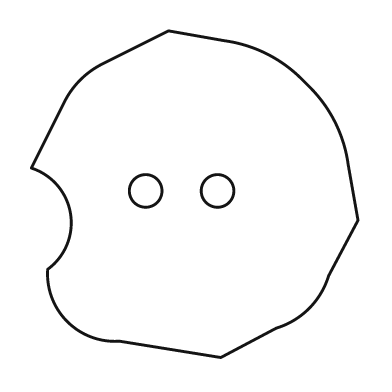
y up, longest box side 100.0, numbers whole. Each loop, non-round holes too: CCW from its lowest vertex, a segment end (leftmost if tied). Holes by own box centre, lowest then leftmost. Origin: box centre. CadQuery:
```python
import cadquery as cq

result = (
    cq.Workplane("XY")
    .moveTo(8.0, -50.0)
    .lineTo(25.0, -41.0)
    .threePointArc((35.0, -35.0), (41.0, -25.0))
    .lineTo(50.0, -8.0)
    .lineTo(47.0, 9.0)
    .threePointArc((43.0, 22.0), (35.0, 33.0))
    .lineTo(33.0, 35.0)
    .threePointArc((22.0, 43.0), (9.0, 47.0))
    .lineTo(-8.0, 50.0)
    .lineTo(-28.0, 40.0)
    .threePointArc((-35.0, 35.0), (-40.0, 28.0))
    .lineTo(-50.0, 8.0)
    .threePointArc((-38.0, -6.0), (-45.0, -23.0))
    .threePointArc((-39.0, -39.0), (-23.0, -45.0))
    .close()
    .moveTo(-15.0, 1.0)
    .circle(5.0)
    .moveTo(7.0, 1.0)
    .circle(5.0)
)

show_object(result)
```